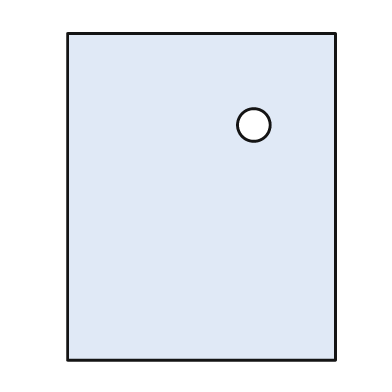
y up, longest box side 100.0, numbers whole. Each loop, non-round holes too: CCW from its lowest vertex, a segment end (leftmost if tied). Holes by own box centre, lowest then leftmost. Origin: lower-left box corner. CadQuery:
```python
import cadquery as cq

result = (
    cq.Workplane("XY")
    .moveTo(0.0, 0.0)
    .lineTo(82.0, 0.0)
    .lineTo(82.0, 100.0)
    .lineTo(0.0, 100.0)
    .close()
    .moveTo(57.0, 72.0)
    .circle(5.0)
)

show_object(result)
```